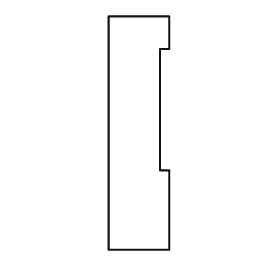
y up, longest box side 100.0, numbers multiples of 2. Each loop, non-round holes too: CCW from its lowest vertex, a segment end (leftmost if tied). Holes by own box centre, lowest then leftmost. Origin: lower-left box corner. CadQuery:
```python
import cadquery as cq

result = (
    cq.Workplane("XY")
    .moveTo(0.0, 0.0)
    .lineTo(26.0, 0.0)
    .lineTo(26.0, 34.0)
    .lineTo(22.0, 34.0)
    .lineTo(22.0, 86.0)
    .lineTo(26.0, 86.0)
    .lineTo(26.0, 100.0)
    .lineTo(0.0, 100.0)
    .close()
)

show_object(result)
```